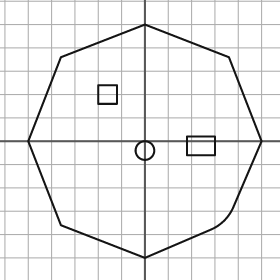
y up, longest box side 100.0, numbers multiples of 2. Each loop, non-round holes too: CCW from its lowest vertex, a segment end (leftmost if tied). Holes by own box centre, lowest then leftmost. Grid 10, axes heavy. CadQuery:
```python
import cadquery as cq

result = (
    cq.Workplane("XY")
    .moveTo(0.0, -50.0)
    .lineTo(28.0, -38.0)
    .threePointArc((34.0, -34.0), (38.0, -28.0))
    .lineTo(50.0, 0.0)
    .lineTo(36.0, 36.0)
    .lineTo(0.0, 50.0)
    .lineTo(-36.0, 36.0)
    .lineTo(-50.0, 0.0)
    .lineTo(-36.0, -36.0)
    .close()
    .moveTo(0.0, -4.0)
    .circle(4.0)
    .moveTo(18.0, -6.0)
    .lineTo(30.0, -6.0)
    .lineTo(30.0, 2.0)
    .lineTo(18.0, 2.0)
    .close()
    .moveTo(-20.0, 16.0)
    .lineTo(-12.0, 16.0)
    .lineTo(-12.0, 24.0)
    .lineTo(-20.0, 24.0)
    .close()
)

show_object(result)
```